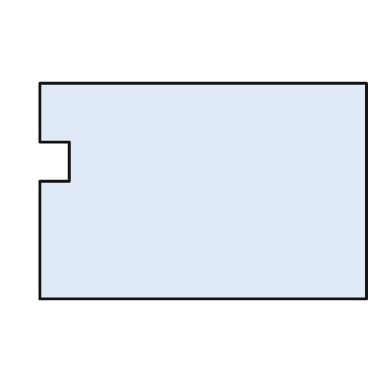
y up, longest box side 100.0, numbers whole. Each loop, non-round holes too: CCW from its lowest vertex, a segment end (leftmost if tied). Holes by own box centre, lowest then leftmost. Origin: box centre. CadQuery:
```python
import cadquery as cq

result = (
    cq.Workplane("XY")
    .moveTo(-50.0, -33.0)
    .lineTo(50.0, -33.0)
    .lineTo(50.0, 33.0)
    .lineTo(-50.0, 33.0)
    .lineTo(-50.0, 15.0)
    .lineTo(-41.0, 15.0)
    .lineTo(-41.0, 3.0)
    .lineTo(-50.0, 3.0)
    .close()
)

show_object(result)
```